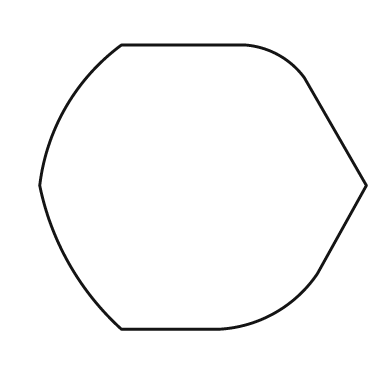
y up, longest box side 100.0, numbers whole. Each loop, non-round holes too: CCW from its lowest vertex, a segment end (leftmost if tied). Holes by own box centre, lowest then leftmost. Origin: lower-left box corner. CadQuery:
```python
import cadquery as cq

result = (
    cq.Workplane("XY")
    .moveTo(25.0, 0.0)
    .lineTo(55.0, 0.0)
    .threePointArc((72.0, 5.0), (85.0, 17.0))
    .lineTo(100.0, 44.0)
    .lineTo(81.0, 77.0)
    .threePointArc((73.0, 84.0), (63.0, 87.0))
    .lineTo(25.0, 87.0)
    .threePointArc((8.0, 68.0), (0.0, 44.0))
    .threePointArc((9.0, 20.0), (25.0, 0.0))
    .close()
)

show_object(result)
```